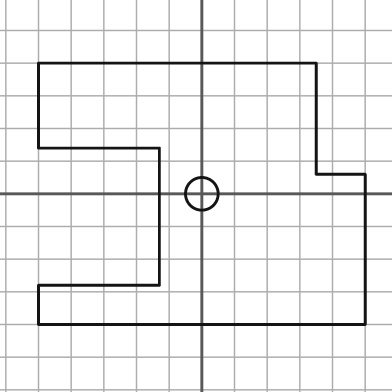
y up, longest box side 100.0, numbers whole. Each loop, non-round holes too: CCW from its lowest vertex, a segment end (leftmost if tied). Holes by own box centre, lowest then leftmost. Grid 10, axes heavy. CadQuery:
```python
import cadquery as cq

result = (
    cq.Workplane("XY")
    .moveTo(-50.0, -40.0)
    .lineTo(50.0, -40.0)
    .lineTo(50.0, 6.0)
    .lineTo(35.0, 6.0)
    .lineTo(35.0, 40.0)
    .lineTo(-50.0, 40.0)
    .lineTo(-50.0, 14.0)
    .lineTo(-13.0, 14.0)
    .lineTo(-13.0, -28.0)
    .lineTo(-50.0, -28.0)
    .close()
    .moveTo(0.0, 0.0)
    .circle(5.0)
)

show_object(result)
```